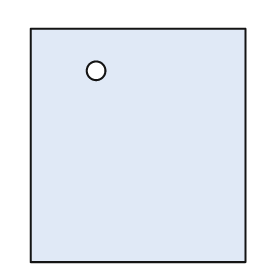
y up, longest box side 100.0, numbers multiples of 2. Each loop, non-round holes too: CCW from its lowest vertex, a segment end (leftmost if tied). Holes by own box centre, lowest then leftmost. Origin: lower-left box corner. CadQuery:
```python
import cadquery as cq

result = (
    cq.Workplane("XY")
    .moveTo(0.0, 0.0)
    .lineTo(92.0, 0.0)
    .lineTo(92.0, 100.0)
    .lineTo(0.0, 100.0)
    .close()
    .moveTo(28.0, 82.0)
    .circle(4.0)
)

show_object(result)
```